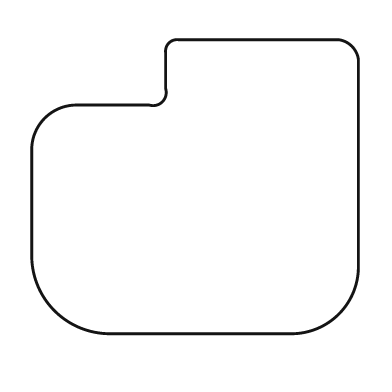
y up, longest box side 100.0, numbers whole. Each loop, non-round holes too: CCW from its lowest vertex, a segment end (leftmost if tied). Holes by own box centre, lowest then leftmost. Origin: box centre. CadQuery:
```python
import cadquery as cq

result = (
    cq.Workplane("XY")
    .moveTo(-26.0, -45.0)
    .lineTo(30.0, -45.0)
    .threePointArc((44.0, -39.0), (50.0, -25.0))
    .lineTo(50.0, 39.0)
    .threePointArc((48.0, 43.0), (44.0, 45.0))
    .lineTo(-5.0, 45.0)
    .threePointArc((-8.0, 44.0), (-9.0, 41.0))
    .lineTo(-9.0, 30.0)
    .threePointArc((-10.0, 26.0), (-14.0, 25.0))
    .lineTo(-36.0, 25.0)
    .threePointArc((-46.0, 21.0), (-50.0, 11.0))
    .lineTo(-50.0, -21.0)
    .threePointArc((-43.0, -38.0), (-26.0, -45.0))
    .close()
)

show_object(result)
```